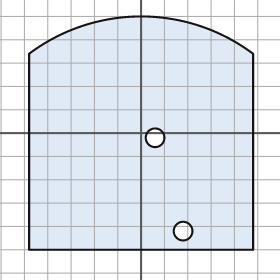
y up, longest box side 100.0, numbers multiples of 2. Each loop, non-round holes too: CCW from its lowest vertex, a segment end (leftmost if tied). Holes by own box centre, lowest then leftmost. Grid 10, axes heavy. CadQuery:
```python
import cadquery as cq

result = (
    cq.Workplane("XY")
    .moveTo(-48.0, -50.0)
    .lineTo(48.0, -50.0)
    .lineTo(48.0, 34.0)
    .threePointArc((0.0, 50.0), (-48.0, 34.0))
    .close()
    .moveTo(18.0, -42.0)
    .circle(4.0)
    .moveTo(6.0, -2.0)
    .circle(4.0)
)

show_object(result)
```